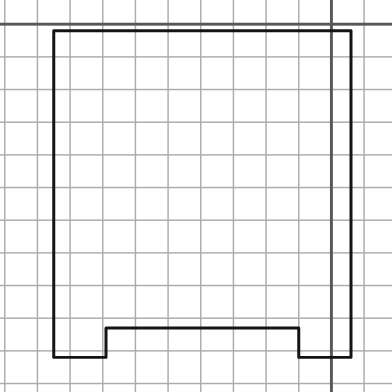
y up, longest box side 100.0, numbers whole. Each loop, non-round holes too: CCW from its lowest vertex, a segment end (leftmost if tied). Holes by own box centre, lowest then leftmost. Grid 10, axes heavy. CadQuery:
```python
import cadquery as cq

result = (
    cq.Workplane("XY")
    .moveTo(-85.0, -102.0)
    .lineTo(-69.0, -102.0)
    .lineTo(-69.0, -93.0)
    .lineTo(-10.0, -93.0)
    .lineTo(-10.0, -102.0)
    .lineTo(6.0, -102.0)
    .lineTo(6.0, -2.0)
    .lineTo(-85.0, -2.0)
    .close()
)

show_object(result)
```